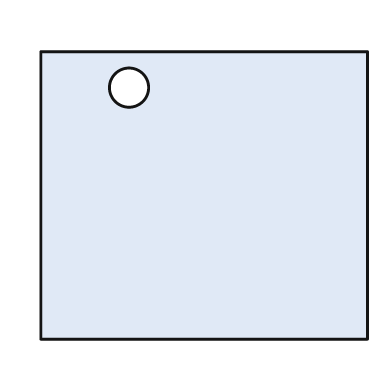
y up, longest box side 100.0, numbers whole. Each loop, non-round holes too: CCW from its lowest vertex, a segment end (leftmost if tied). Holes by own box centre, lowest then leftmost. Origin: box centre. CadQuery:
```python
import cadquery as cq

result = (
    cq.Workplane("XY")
    .moveTo(-50.0, -44.0)
    .lineTo(50.0, -44.0)
    .lineTo(50.0, 44.0)
    .lineTo(-50.0, 44.0)
    .close()
    .moveTo(-23.0, 33.0)
    .circle(6.0)
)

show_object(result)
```